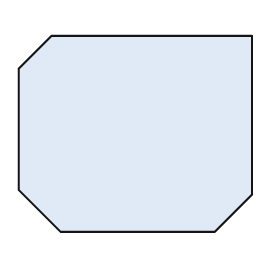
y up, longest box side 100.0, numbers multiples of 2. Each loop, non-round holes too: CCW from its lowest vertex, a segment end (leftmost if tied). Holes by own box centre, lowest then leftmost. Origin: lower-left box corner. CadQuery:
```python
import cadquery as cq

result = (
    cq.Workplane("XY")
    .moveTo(18.0, 0.0)
    .lineTo(84.0, 0.0)
    .lineTo(100.0, 16.0)
    .lineTo(100.0, 84.0)
    .lineTo(14.0, 84.0)
    .lineTo(0.0, 70.0)
    .lineTo(0.0, 18.0)
    .close()
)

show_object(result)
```